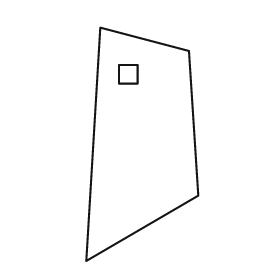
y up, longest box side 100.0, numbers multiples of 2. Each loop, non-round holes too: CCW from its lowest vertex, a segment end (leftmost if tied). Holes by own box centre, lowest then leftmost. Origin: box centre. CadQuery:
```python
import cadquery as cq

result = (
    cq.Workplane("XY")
    .moveTo(-24.0, -50.0)
    .lineTo(24.0, -22.0)
    .lineTo(20.0, 40.0)
    .lineTo(-18.0, 50.0)
    .close()
    .moveTo(-10.0, 26.0)
    .lineTo(-2.0, 26.0)
    .lineTo(-2.0, 34.0)
    .lineTo(-10.0, 34.0)
    .close()
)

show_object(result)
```